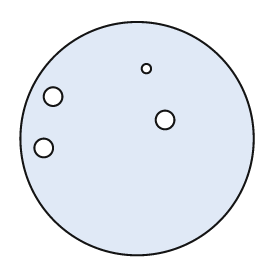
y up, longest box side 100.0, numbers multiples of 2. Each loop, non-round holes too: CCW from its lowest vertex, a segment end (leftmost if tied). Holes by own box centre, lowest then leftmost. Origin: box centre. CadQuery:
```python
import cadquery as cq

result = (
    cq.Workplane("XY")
    .moveTo(0.0, 0.0)
    .circle(50.0)
    .moveTo(-40.0, -4.0)
    .circle(4.0)
    .moveTo(12.0, 8.0)
    .circle(4.0)
    .moveTo(-36.0, 18.0)
    .circle(4.0)
    .moveTo(4.0, 30.0)
    .circle(2.0)
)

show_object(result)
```